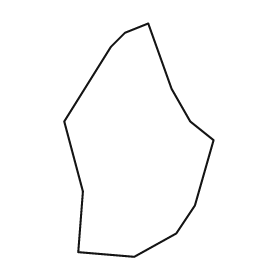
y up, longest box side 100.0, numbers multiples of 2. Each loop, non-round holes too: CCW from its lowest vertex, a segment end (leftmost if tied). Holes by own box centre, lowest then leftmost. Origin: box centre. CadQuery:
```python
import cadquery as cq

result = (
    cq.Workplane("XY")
    .moveTo(-2.0, -50.0)
    .lineTo(16.0, -40.0)
    .lineTo(24.0, -28.0)
    .lineTo(32.0, 0.0)
    .lineTo(22.0, 8.0)
    .lineTo(14.0, 22.0)
    .lineTo(4.0, 50.0)
    .lineTo(-6.0, 46.0)
    .lineTo(-12.0, 40.0)
    .lineTo(-32.0, 8.0)
    .lineTo(-24.0, -22.0)
    .lineTo(-26.0, -48.0)
    .close()
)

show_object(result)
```